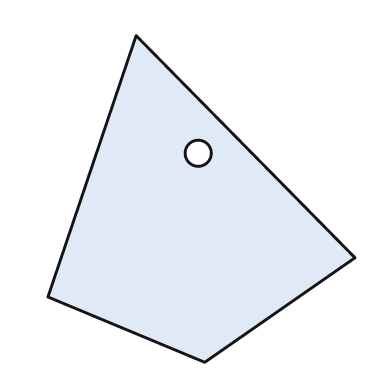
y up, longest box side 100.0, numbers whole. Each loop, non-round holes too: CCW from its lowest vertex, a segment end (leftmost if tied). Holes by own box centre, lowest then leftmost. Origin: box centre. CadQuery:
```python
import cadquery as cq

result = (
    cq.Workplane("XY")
    .moveTo(1.0, -50.0)
    .lineTo(47.0, -18.0)
    .lineTo(-20.0, 50.0)
    .lineTo(-47.0, -30.0)
    .close()
    .moveTo(-1.0, 14.0)
    .circle(4.0)
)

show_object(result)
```